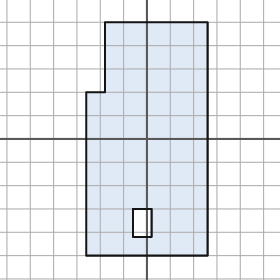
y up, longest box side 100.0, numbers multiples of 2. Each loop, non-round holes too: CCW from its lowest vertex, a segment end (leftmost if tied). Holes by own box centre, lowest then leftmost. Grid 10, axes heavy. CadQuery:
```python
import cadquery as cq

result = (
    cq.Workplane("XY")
    .moveTo(-26.0, -50.0)
    .lineTo(26.0, -50.0)
    .lineTo(26.0, 50.0)
    .lineTo(-18.0, 50.0)
    .lineTo(-18.0, 20.0)
    .lineTo(-26.0, 20.0)
    .close()
    .moveTo(-6.0, -42.0)
    .lineTo(2.0, -42.0)
    .lineTo(2.0, -30.0)
    .lineTo(-6.0, -30.0)
    .close()
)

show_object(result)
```